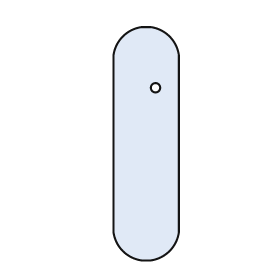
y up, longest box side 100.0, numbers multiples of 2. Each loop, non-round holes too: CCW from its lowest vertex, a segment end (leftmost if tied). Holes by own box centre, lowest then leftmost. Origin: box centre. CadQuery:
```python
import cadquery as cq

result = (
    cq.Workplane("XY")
    .moveTo(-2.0, -50.0)
    .lineTo(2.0, -50.0)
    .threePointArc((10.0, -46.0), (14.0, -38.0))
    .lineTo(14.0, 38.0)
    .threePointArc((10.0, 46.0), (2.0, 50.0))
    .lineTo(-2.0, 50.0)
    .threePointArc((-10.0, 46.0), (-14.0, 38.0))
    .lineTo(-14.0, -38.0)
    .threePointArc((-10.0, -46.0), (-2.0, -50.0))
    .close()
    .moveTo(4.0, 24.0)
    .circle(2.0)
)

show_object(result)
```